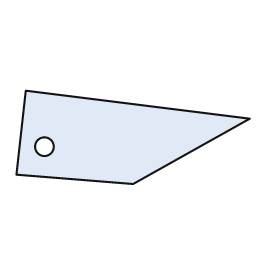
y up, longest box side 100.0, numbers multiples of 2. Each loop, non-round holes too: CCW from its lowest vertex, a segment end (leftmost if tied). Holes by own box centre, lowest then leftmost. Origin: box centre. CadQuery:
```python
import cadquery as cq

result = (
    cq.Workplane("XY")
    .moveTo(0.0, -20.0)
    .lineTo(50.0, 8.0)
    .lineTo(-46.0, 20.0)
    .lineTo(-50.0, -16.0)
    .close()
    .moveTo(-38.0, -4.0)
    .circle(4.0)
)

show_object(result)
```